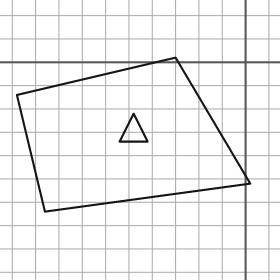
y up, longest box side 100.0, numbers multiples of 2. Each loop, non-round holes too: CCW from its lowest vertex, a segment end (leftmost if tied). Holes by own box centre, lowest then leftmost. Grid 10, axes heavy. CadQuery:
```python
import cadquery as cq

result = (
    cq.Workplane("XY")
    .moveTo(-86.0, -64.0)
    .lineTo(2.0, -52.0)
    .lineTo(-30.0, 2.0)
    .lineTo(-98.0, -14.0)
    .close()
    .moveTo(-54.0, -34.0)
    .lineTo(-42.0, -34.0)
    .lineTo(-48.0, -22.0)
    .close()
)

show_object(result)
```